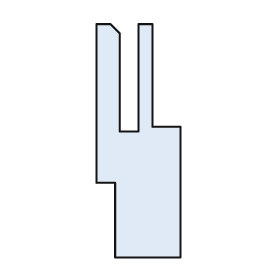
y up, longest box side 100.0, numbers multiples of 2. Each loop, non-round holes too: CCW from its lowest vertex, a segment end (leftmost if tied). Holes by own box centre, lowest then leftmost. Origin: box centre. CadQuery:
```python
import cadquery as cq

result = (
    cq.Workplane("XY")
    .moveTo(-10.0, -50.0)
    .lineTo(18.0, -50.0)
    .lineTo(18.0, 6.0)
    .lineTo(6.0, 6.0)
    .lineTo(6.0, 50.0)
    .lineTo(0.0, 50.0)
    .lineTo(0.0, 4.0)
    .lineTo(-8.0, 4.0)
    .lineTo(-8.0, 46.0)
    .lineTo(-12.0, 50.0)
    .lineTo(-18.0, 50.0)
    .lineTo(-18.0, -18.0)
    .lineTo(-10.0, -18.0)
    .close()
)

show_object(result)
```